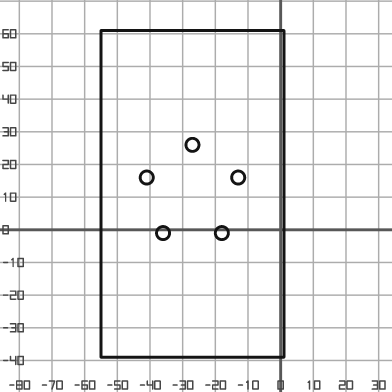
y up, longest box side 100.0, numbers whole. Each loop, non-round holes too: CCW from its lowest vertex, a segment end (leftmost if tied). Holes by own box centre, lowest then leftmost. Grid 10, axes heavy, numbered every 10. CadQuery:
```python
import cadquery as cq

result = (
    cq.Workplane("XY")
    .moveTo(-55.0, -39.0)
    .lineTo(1.0, -39.0)
    .lineTo(1.0, 61.0)
    .lineTo(-55.0, 61.0)
    .close()
    .moveTo(-36.0, -1.0)
    .circle(2.0)
    .moveTo(-18.0, -1.0)
    .circle(2.0)
    .moveTo(-41.0, 16.0)
    .circle(2.0)
    .moveTo(-13.0, 16.0)
    .circle(2.0)
    .moveTo(-27.0, 26.0)
    .circle(2.0)
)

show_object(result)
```